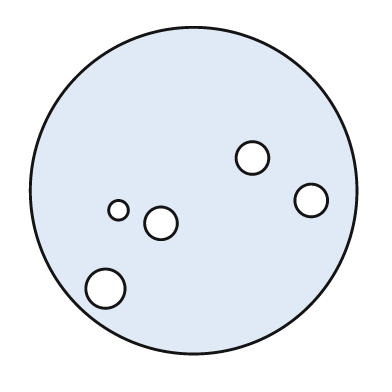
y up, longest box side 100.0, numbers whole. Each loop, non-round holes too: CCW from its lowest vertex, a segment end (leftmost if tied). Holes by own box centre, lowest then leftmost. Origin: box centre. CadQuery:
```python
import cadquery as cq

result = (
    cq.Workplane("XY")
    .moveTo(0.0, 0.0)
    .circle(50.0)
    .moveTo(-27.0, -30.0)
    .circle(6.0)
    .moveTo(-10.0, -10.0)
    .circle(5.0)
    .moveTo(-23.0, -6.0)
    .circle(3.0)
    .moveTo(36.0, -3.0)
    .circle(5.0)
    .moveTo(18.0, 10.0)
    .circle(5.0)
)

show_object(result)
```